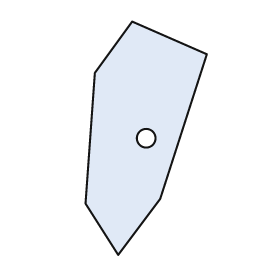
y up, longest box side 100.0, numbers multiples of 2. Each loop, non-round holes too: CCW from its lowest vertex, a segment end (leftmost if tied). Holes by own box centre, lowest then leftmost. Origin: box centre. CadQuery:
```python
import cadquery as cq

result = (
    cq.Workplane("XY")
    .moveTo(-12.0, -50.0)
    .lineTo(6.0, -26.0)
    .lineTo(26.0, 36.0)
    .lineTo(-6.0, 50.0)
    .lineTo(-22.0, 28.0)
    .lineTo(-26.0, -28.0)
    .close()
    .moveTo(0.0, 0.0)
    .circle(4.0)
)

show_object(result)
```